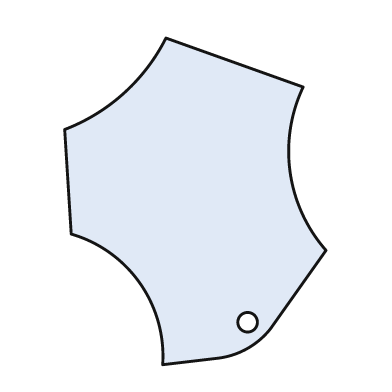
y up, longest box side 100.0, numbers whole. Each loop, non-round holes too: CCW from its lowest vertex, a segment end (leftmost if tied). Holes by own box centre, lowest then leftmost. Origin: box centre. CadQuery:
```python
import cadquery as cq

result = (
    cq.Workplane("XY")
    .moveTo(-10.0, -50.0)
    .lineTo(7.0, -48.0)
    .threePointArc((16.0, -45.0), (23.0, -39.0))
    .lineTo(40.0, -15.0)
    .threePointArc((29.0, 9.0), (33.0, 35.0))
    .lineTo(-9.0, 50.0)
    .threePointArc((-22.0, 33.0), (-40.0, 22.0))
    .lineTo(-38.0, -10.0)
    .threePointArc((-17.0, -25.0), (-10.0, -50.0))
    .close()
    .moveTo(16.0, -37.0)
    .circle(3.0)
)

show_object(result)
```